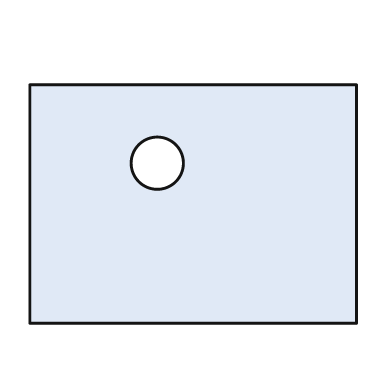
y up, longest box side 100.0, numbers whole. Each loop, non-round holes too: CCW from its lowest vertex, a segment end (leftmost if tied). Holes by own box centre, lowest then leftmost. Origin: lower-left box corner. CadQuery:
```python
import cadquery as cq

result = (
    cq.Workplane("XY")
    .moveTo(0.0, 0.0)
    .lineTo(100.0, 0.0)
    .lineTo(100.0, 73.0)
    .lineTo(0.0, 73.0)
    .close()
    .moveTo(39.0, 49.0)
    .circle(8.0)
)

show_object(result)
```